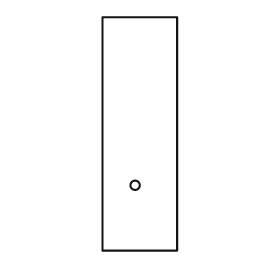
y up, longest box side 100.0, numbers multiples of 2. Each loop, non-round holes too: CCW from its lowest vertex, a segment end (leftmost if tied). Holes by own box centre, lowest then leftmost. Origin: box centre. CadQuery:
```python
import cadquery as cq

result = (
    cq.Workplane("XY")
    .moveTo(-16.0, -50.0)
    .lineTo(16.0, -50.0)
    .lineTo(16.0, 50.0)
    .lineTo(-16.0, 50.0)
    .close()
    .moveTo(-2.0, -22.0)
    .circle(2.0)
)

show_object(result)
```